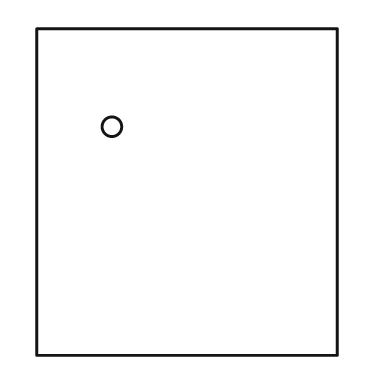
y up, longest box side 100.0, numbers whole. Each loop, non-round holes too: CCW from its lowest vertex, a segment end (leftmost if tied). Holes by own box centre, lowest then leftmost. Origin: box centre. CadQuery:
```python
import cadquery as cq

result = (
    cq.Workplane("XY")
    .moveTo(-46.0, -50.0)
    .lineTo(46.0, -50.0)
    .lineTo(46.0, 50.0)
    .lineTo(-46.0, 50.0)
    .close()
    .moveTo(-23.0, 20.0)
    .circle(3.0)
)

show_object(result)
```